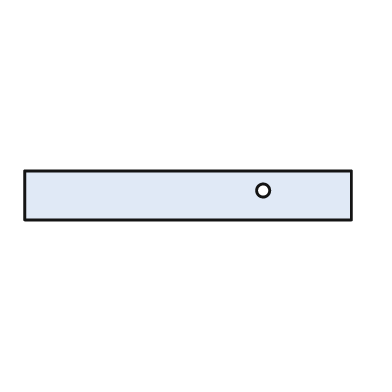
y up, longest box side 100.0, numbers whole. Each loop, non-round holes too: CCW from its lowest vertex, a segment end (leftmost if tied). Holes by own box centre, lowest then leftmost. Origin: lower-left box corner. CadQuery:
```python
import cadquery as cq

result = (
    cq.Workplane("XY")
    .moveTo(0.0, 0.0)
    .lineTo(100.0, 0.0)
    .lineTo(100.0, 15.0)
    .lineTo(0.0, 15.0)
    .close()
    .moveTo(73.0, 9.0)
    .circle(2.0)
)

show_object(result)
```